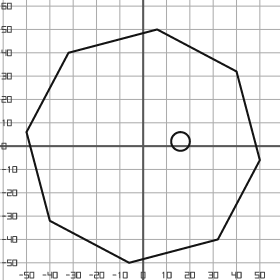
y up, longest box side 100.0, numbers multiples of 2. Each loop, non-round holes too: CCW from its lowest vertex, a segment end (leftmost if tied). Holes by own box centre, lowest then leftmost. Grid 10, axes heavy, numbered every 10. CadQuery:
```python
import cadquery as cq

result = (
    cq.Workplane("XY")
    .moveTo(-6.0, -50.0)
    .lineTo(32.0, -40.0)
    .lineTo(50.0, -6.0)
    .lineTo(40.0, 32.0)
    .lineTo(6.0, 50.0)
    .lineTo(-32.0, 40.0)
    .lineTo(-50.0, 6.0)
    .lineTo(-40.0, -32.0)
    .close()
    .moveTo(16.0, 2.0)
    .circle(4.0)
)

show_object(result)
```